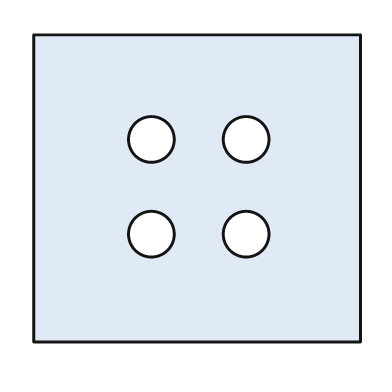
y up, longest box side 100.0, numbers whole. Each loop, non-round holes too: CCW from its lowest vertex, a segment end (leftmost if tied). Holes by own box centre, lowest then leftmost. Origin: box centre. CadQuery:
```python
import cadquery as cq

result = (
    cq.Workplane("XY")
    .moveTo(-50.0, -47.0)
    .lineTo(50.0, -47.0)
    .lineTo(50.0, 47.0)
    .lineTo(-50.0, 47.0)
    .close()
    .moveTo(-14.0, -14.0)
    .circle(7.0)
    .moveTo(15.0, -14.0)
    .circle(7.0)
    .moveTo(-14.0, 15.0)
    .circle(7.0)
    .moveTo(15.0, 15.0)
    .circle(7.0)
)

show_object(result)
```